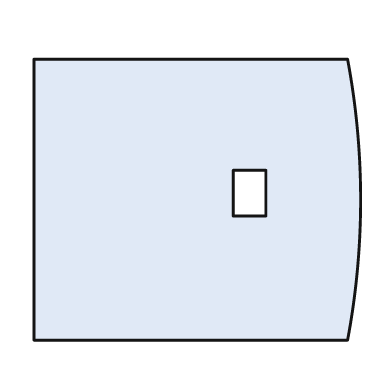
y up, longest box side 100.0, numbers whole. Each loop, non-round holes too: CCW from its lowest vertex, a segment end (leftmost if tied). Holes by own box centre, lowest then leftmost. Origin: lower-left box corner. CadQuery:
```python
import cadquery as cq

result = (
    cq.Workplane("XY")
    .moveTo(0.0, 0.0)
    .lineTo(96.0, 0.0)
    .threePointArc((100.0, 43.0), (96.0, 86.0))
    .lineTo(0.0, 86.0)
    .close()
    .moveTo(61.0, 38.0)
    .lineTo(71.0, 38.0)
    .lineTo(71.0, 52.0)
    .lineTo(61.0, 52.0)
    .close()
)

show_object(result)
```